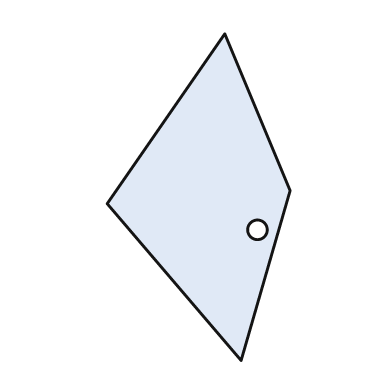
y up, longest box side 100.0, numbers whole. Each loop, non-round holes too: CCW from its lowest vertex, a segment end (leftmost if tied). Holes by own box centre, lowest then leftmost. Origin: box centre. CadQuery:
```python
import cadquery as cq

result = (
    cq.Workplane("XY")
    .moveTo(13.0, -50.0)
    .lineTo(28.0, 2.0)
    .lineTo(8.0, 50.0)
    .lineTo(-28.0, -2.0)
    .close()
    .moveTo(18.0, -10.0)
    .circle(3.0)
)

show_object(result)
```